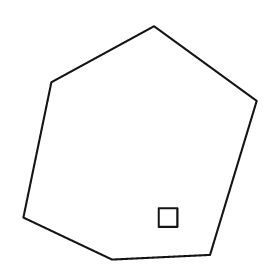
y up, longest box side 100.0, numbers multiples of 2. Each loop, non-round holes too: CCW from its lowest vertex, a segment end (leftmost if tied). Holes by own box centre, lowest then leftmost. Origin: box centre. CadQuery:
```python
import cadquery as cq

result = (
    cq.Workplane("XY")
    .moveTo(-12.0, -50.0)
    .lineTo(30.0, -48.0)
    .lineTo(50.0, 18.0)
    .lineTo(6.0, 50.0)
    .lineTo(-38.0, 26.0)
    .lineTo(-50.0, -32.0)
    .close()
    .moveTo(8.0, -36.0)
    .lineTo(16.0, -36.0)
    .lineTo(16.0, -28.0)
    .lineTo(8.0, -28.0)
    .close()
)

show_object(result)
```